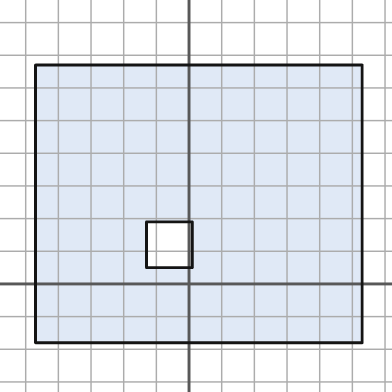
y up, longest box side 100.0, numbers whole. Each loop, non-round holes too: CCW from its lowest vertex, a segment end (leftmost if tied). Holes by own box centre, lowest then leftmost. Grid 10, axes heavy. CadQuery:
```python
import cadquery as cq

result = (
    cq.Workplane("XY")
    .moveTo(-47.0, -18.0)
    .lineTo(53.0, -18.0)
    .lineTo(53.0, 67.0)
    .lineTo(-47.0, 67.0)
    .close()
    .moveTo(-13.0, 5.0)
    .lineTo(1.0, 5.0)
    .lineTo(1.0, 19.0)
    .lineTo(-13.0, 19.0)
    .close()
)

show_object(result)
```